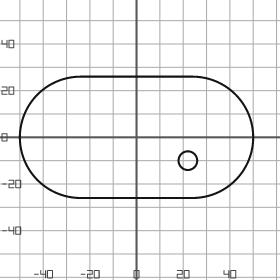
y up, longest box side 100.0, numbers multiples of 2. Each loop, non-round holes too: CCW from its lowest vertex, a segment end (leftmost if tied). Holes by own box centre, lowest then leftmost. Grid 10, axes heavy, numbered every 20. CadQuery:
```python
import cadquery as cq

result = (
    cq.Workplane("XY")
    .moveTo(-24.0, -26.0)
    .lineTo(24.0, -26.0)
    .threePointArc((50.0, 0.0), (24.0, 26.0))
    .lineTo(-24.0, 26.0)
    .threePointArc((-50.0, 0.0), (-24.0, -26.0))
    .close()
    .moveTo(22.0, -10.0)
    .circle(4.0)
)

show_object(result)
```